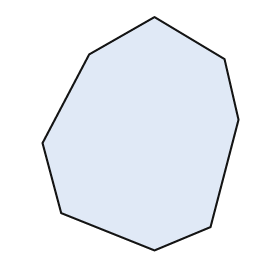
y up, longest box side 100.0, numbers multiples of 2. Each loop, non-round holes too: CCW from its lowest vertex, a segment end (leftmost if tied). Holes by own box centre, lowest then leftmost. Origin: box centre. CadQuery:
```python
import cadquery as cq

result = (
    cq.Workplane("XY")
    .moveTo(6.0, -50.0)
    .lineTo(30.0, -40.0)
    .lineTo(42.0, 6.0)
    .lineTo(36.0, 32.0)
    .lineTo(6.0, 50.0)
    .lineTo(-22.0, 34.0)
    .lineTo(-42.0, -4.0)
    .lineTo(-34.0, -34.0)
    .close()
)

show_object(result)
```